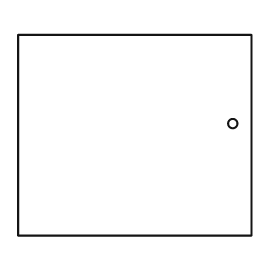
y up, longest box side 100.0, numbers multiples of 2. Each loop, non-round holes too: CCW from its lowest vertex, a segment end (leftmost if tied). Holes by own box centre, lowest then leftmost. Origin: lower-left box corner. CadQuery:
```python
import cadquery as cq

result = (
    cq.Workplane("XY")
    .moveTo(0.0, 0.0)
    .lineTo(100.0, 0.0)
    .lineTo(100.0, 86.0)
    .lineTo(0.0, 86.0)
    .close()
    .moveTo(92.0, 48.0)
    .circle(2.0)
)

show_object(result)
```